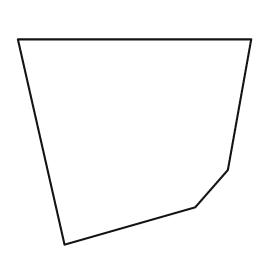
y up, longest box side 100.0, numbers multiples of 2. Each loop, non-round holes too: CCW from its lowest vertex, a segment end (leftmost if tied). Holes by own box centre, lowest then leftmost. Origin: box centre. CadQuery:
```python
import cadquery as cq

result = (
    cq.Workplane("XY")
    .moveTo(-30.0, -44.0)
    .lineTo(26.0, -28.0)
    .lineTo(40.0, -12.0)
    .lineTo(50.0, 44.0)
    .lineTo(-50.0, 44.0)
    .close()
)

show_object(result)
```